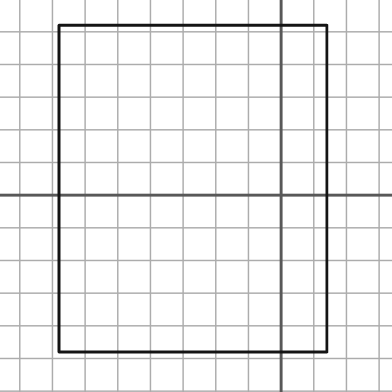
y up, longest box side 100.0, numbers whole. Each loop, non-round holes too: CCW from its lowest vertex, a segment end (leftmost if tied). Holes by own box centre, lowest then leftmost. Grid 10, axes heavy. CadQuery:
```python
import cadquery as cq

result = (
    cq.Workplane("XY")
    .moveTo(-68.0, -48.0)
    .lineTo(14.0, -48.0)
    .lineTo(14.0, 52.0)
    .lineTo(-68.0, 52.0)
    .close()
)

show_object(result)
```